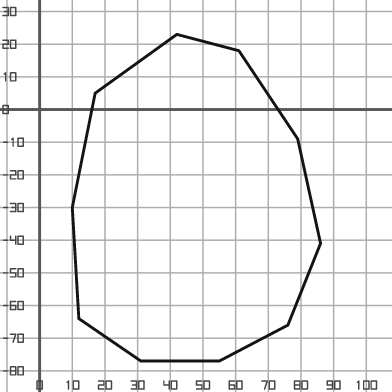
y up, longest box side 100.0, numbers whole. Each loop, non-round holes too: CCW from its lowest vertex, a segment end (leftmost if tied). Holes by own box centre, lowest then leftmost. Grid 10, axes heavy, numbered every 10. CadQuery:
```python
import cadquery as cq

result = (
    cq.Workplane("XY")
    .moveTo(31.0, -77.0)
    .lineTo(55.0, -77.0)
    .lineTo(76.0, -66.0)
    .lineTo(86.0, -41.0)
    .lineTo(79.0, -9.0)
    .lineTo(61.0, 18.0)
    .lineTo(42.0, 23.0)
    .lineTo(17.0, 5.0)
    .lineTo(10.0, -30.0)
    .lineTo(12.0, -64.0)
    .close()
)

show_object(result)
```